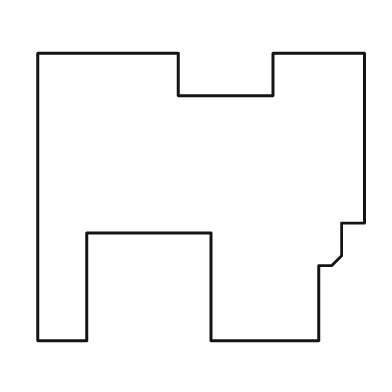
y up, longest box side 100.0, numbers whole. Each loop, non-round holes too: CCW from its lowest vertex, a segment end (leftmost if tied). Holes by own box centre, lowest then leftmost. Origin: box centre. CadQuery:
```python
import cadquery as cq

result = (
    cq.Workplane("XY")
    .moveTo(-50.0, -44.0)
    .lineTo(-35.0, -44.0)
    .lineTo(-35.0, -11.0)
    .lineTo(3.0, -11.0)
    .lineTo(3.0, -44.0)
    .lineTo(36.0, -44.0)
    .lineTo(36.0, -21.0)
    .lineTo(40.0, -21.0)
    .lineTo(43.0, -18.0)
    .lineTo(43.0, -8.0)
    .lineTo(50.0, -8.0)
    .lineTo(50.0, 44.0)
    .lineTo(22.0, 44.0)
    .lineTo(22.0, 31.0)
    .lineTo(-7.0, 31.0)
    .lineTo(-7.0, 44.0)
    .lineTo(-50.0, 44.0)
    .close()
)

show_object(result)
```